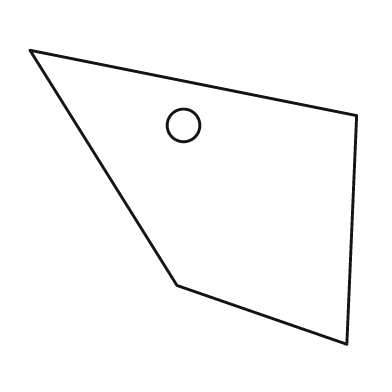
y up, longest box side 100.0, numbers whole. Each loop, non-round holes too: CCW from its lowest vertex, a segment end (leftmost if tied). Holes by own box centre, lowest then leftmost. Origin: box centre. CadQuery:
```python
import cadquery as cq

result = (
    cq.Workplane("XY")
    .moveTo(47.0, -45.0)
    .lineTo(50.0, 25.0)
    .lineTo(-50.0, 45.0)
    .lineTo(-5.0, -27.0)
    .close()
    .moveTo(-3.0, 22.0)
    .circle(5.0)
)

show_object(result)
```